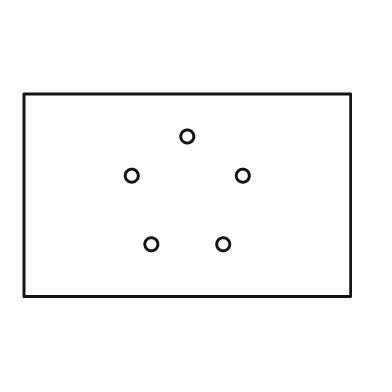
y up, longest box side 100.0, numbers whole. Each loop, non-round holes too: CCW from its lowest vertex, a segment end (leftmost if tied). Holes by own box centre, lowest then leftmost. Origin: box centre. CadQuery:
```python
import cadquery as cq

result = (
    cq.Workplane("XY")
    .moveTo(-50.0, -31.0)
    .lineTo(50.0, -31.0)
    .lineTo(50.0, 31.0)
    .lineTo(-50.0, 31.0)
    .close()
    .moveTo(-11.0, -15.0)
    .circle(2.0)
    .moveTo(11.0, -15.0)
    .circle(2.0)
    .moveTo(-17.0, 6.0)
    .circle(2.0)
    .moveTo(17.0, 6.0)
    .circle(2.0)
    .moveTo(0.0, 18.0)
    .circle(2.0)
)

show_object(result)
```